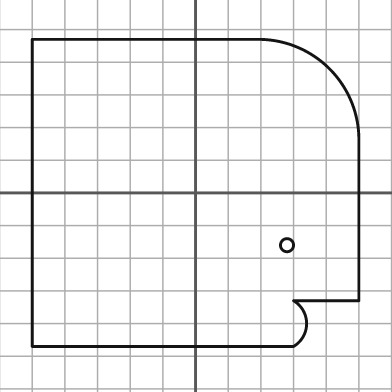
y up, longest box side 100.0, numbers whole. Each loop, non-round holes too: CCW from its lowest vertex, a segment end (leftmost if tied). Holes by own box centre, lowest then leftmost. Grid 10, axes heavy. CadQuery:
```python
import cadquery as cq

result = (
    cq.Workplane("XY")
    .moveTo(-50.0, -47.0)
    .lineTo(30.0, -47.0)
    .threePointArc((34.0, -40.0), (30.0, -33.0))
    .lineTo(50.0, -33.0)
    .lineTo(50.0, 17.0)
    .threePointArc((41.0, 38.0), (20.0, 47.0))
    .lineTo(-50.0, 47.0)
    .close()
    .moveTo(28.0, -16.0)
    .circle(2.0)
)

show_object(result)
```